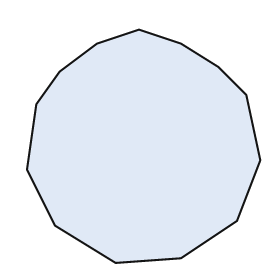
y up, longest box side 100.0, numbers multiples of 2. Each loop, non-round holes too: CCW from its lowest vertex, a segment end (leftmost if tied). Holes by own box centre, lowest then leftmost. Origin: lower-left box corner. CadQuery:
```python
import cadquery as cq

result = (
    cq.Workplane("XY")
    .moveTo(38.0, 0.0)
    .lineTo(66.0, 2.0)
    .lineTo(90.0, 18.0)
    .lineTo(100.0, 44.0)
    .lineTo(94.0, 72.0)
    .lineTo(82.0, 84.0)
    .lineTo(66.0, 94.0)
    .lineTo(48.0, 100.0)
    .lineTo(30.0, 94.0)
    .lineTo(14.0, 82.0)
    .lineTo(4.0, 68.0)
    .lineTo(0.0, 40.0)
    .lineTo(12.0, 16.0)
    .close()
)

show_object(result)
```